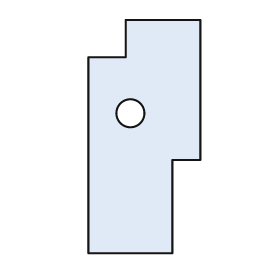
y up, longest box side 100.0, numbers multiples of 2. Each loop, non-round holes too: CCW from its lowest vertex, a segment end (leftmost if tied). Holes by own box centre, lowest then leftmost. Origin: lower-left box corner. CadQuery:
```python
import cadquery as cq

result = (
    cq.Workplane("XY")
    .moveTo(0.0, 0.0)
    .lineTo(36.0, 0.0)
    .lineTo(36.0, 40.0)
    .lineTo(48.0, 40.0)
    .lineTo(48.0, 100.0)
    .lineTo(16.0, 100.0)
    .lineTo(16.0, 84.0)
    .lineTo(0.0, 84.0)
    .close()
    .moveTo(18.0, 60.0)
    .circle(6.0)
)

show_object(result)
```